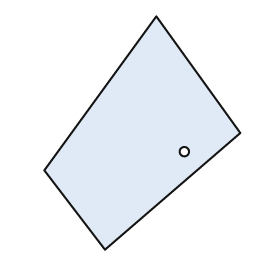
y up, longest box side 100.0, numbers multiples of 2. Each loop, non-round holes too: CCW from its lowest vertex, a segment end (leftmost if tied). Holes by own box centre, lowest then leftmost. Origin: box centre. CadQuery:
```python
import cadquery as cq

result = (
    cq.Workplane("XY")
    .moveTo(-16.0, -50.0)
    .lineTo(42.0, 0.0)
    .lineTo(6.0, 50.0)
    .lineTo(-42.0, -16.0)
    .close()
    .moveTo(18.0, -8.0)
    .circle(2.0)
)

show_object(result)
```